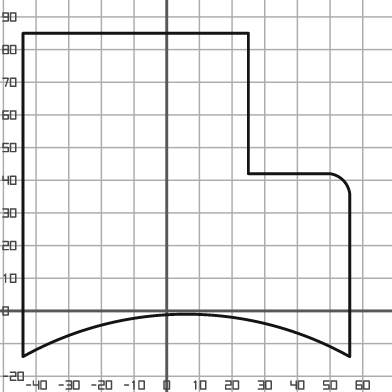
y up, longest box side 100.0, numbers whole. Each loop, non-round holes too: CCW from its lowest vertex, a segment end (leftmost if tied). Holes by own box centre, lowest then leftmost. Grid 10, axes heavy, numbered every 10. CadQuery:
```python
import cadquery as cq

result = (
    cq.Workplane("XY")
    .moveTo(-44.0, -14.0)
    .threePointArc((6.0, -1.0), (56.0, -14.0))
    .lineTo(56.0, 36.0)
    .threePointArc((54.0, 40.0), (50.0, 42.0))
    .lineTo(25.0, 42.0)
    .lineTo(25.0, 85.0)
    .lineTo(-44.0, 85.0)
    .close()
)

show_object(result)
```